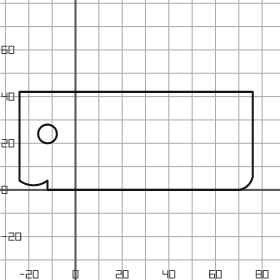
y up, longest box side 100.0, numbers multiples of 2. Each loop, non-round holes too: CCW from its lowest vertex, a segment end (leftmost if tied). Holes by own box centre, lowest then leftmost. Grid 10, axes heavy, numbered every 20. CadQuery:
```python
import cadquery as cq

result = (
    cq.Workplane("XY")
    .moveTo(-12.0, 0.0)
    .lineTo(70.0, 0.0)
    .threePointArc((74.0, 2.0), (76.0, 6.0))
    .lineTo(76.0, 42.0)
    .lineTo(-24.0, 42.0)
    .lineTo(-24.0, 4.0)
    .threePointArc((-18.0, 2.0), (-12.0, 4.0))
    .close()
    .moveTo(-12.0, 24.0)
    .circle(4.0)
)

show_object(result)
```